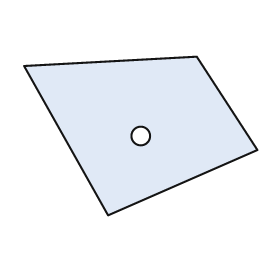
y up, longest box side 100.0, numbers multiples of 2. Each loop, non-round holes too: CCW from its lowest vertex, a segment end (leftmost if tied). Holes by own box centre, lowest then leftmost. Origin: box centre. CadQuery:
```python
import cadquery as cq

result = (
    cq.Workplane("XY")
    .moveTo(-14.0, -34.0)
    .lineTo(50.0, -6.0)
    .lineTo(24.0, 34.0)
    .lineTo(-50.0, 30.0)
    .close()
    .moveTo(0.0, 0.0)
    .circle(4.0)
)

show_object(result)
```